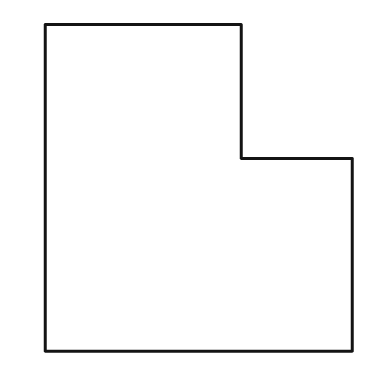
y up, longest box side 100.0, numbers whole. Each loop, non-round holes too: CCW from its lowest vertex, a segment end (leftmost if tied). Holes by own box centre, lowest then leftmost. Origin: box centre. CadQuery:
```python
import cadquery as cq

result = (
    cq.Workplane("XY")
    .moveTo(-47.0, -50.0)
    .lineTo(47.0, -50.0)
    .lineTo(47.0, 9.0)
    .lineTo(13.0, 9.0)
    .lineTo(13.0, 50.0)
    .lineTo(-47.0, 50.0)
    .close()
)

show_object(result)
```